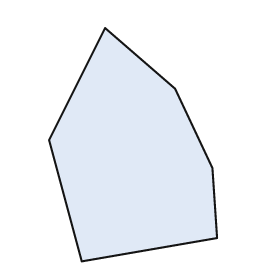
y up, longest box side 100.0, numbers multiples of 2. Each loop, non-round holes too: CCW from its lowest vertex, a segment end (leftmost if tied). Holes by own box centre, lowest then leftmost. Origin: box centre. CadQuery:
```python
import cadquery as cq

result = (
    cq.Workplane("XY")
    .moveTo(-22.0, -50.0)
    .lineTo(36.0, -40.0)
    .lineTo(34.0, -10.0)
    .lineTo(18.0, 24.0)
    .lineTo(-12.0, 50.0)
    .lineTo(-36.0, 2.0)
    .close()
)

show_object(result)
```